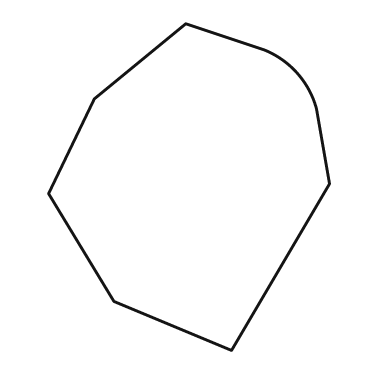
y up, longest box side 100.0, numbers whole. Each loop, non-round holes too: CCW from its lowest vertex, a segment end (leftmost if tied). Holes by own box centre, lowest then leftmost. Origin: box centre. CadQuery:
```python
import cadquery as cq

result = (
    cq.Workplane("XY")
    .moveTo(13.0, -50.0)
    .lineTo(43.0, 1.0)
    .lineTo(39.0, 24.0)
    .threePointArc((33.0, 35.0), (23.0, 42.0))
    .lineTo(-1.0, 50.0)
    .lineTo(-29.0, 27.0)
    .lineTo(-43.0, -2.0)
    .lineTo(-23.0, -35.0)
    .close()
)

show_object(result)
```